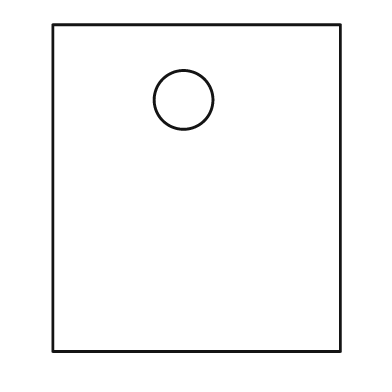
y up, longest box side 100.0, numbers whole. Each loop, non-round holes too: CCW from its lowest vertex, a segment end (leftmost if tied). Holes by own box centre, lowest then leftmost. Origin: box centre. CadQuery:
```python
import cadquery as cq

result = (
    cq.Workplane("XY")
    .moveTo(-44.0, -50.0)
    .lineTo(44.0, -50.0)
    .lineTo(44.0, 50.0)
    .lineTo(-44.0, 50.0)
    .close()
    .moveTo(-4.0, 27.0)
    .circle(9.0)
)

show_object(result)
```